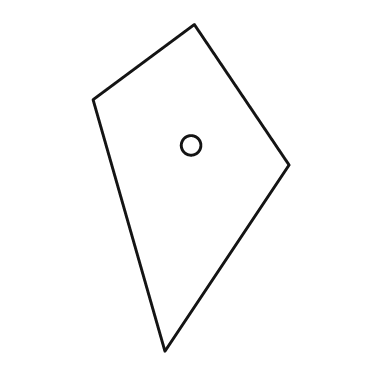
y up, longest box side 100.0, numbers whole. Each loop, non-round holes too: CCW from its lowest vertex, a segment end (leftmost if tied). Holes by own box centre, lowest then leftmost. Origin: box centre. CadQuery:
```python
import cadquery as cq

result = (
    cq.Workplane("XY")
    .moveTo(-8.0, -50.0)
    .lineTo(30.0, 7.0)
    .lineTo(1.0, 50.0)
    .lineTo(-30.0, 27.0)
    .close()
    .moveTo(0.0, 13.0)
    .circle(3.0)
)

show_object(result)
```